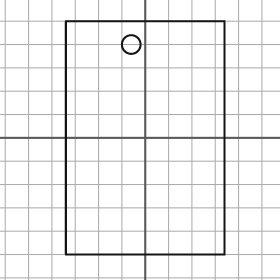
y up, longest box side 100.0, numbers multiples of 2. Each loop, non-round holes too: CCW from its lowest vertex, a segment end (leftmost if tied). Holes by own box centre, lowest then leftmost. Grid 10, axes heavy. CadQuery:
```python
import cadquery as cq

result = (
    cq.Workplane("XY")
    .moveTo(-34.0, -50.0)
    .lineTo(34.0, -50.0)
    .lineTo(34.0, 50.0)
    .lineTo(-34.0, 50.0)
    .close()
    .moveTo(-6.0, 40.0)
    .circle(4.0)
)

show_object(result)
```